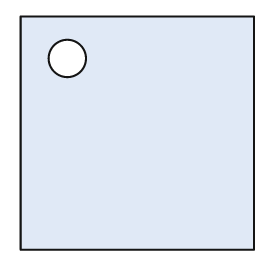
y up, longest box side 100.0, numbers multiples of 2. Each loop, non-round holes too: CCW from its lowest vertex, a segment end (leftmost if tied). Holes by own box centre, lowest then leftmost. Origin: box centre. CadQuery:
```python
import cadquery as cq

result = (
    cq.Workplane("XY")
    .moveTo(-50.0, -50.0)
    .lineTo(50.0, -50.0)
    .lineTo(50.0, 50.0)
    .lineTo(-50.0, 50.0)
    .close()
    .moveTo(-30.0, 32.0)
    .circle(8.0)
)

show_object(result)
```